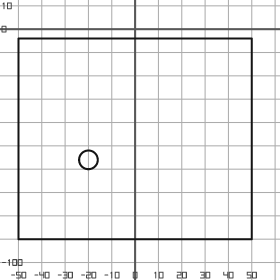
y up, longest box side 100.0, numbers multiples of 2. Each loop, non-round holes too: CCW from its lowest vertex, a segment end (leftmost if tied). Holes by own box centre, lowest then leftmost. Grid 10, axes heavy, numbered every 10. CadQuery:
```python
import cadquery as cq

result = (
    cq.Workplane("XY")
    .moveTo(-50.0, -90.0)
    .lineTo(50.0, -90.0)
    .lineTo(50.0, -4.0)
    .lineTo(-50.0, -4.0)
    .close()
    .moveTo(-20.0, -56.0)
    .circle(4.0)
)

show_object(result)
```